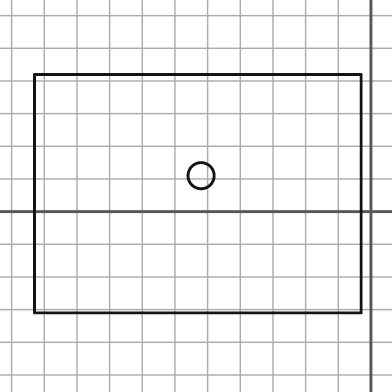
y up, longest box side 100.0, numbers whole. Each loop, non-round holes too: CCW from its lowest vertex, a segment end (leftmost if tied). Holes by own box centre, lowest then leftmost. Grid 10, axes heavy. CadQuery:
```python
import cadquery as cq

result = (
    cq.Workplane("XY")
    .moveTo(-103.0, -31.0)
    .lineTo(-3.0, -31.0)
    .lineTo(-3.0, 42.0)
    .lineTo(-103.0, 42.0)
    .close()
    .moveTo(-52.0, 11.0)
    .circle(4.0)
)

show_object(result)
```